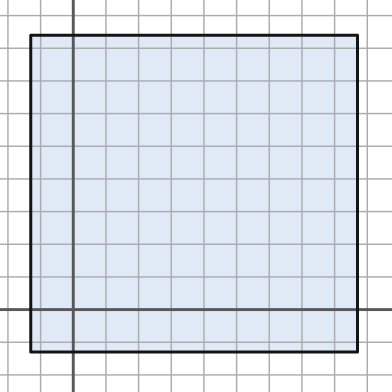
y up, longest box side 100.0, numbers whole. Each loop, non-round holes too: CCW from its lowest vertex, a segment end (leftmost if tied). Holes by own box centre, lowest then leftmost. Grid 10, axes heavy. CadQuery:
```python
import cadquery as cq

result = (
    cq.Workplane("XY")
    .moveTo(-13.0, -13.0)
    .lineTo(87.0, -13.0)
    .lineTo(87.0, 84.0)
    .lineTo(-13.0, 84.0)
    .close()
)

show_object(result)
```